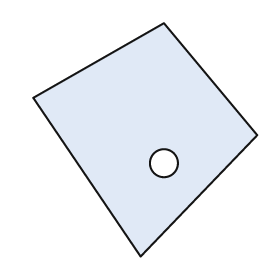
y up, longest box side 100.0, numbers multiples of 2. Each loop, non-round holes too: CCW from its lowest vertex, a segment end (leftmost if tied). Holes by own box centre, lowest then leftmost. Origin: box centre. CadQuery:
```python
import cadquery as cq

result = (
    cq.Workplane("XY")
    .moveTo(-2.0, -50.0)
    .lineTo(48.0, 2.0)
    .lineTo(8.0, 50.0)
    .lineTo(-48.0, 18.0)
    .close()
    .moveTo(8.0, -10.0)
    .circle(6.0)
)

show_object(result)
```